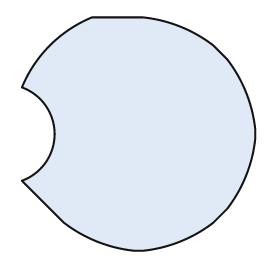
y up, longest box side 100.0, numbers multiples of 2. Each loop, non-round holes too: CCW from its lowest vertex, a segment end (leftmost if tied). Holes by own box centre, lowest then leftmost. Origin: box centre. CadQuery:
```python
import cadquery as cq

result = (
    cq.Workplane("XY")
    .moveTo(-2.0, -50.0)
    .lineTo(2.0, -50.0)
    .threePointArc((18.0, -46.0), (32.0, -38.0))
    .lineTo(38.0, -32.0)
    .threePointArc((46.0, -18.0), (50.0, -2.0))
    .lineTo(50.0, 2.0)
    .threePointArc((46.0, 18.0), (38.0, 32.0))
    .lineTo(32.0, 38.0)
    .threePointArc((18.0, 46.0), (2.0, 50.0))
    .lineTo(-20.0, 50.0)
    .threePointArc((-38.0, 38.0), (-50.0, 20.0))
    .threePointArc((-36.0, 0.0), (-50.0, -20.0))
    .lineTo(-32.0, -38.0)
    .threePointArc((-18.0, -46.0), (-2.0, -50.0))
    .close()
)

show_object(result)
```